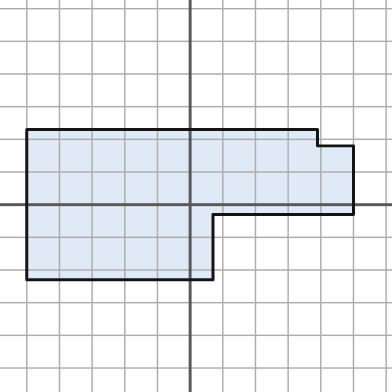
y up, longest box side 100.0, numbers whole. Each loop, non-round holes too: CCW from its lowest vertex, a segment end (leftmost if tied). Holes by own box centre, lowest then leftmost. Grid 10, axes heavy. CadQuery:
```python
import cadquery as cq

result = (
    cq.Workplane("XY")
    .moveTo(-50.0, -23.0)
    .lineTo(7.0, -23.0)
    .lineTo(7.0, -3.0)
    .lineTo(50.0, -3.0)
    .lineTo(50.0, 18.0)
    .lineTo(39.0, 18.0)
    .lineTo(39.0, 23.0)
    .lineTo(-50.0, 23.0)
    .close()
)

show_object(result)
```